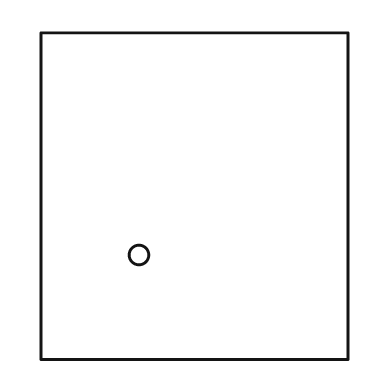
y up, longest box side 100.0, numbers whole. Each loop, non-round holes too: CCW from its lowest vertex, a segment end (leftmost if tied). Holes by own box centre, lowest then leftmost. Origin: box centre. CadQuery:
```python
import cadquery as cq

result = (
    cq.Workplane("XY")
    .moveTo(-47.0, -50.0)
    .lineTo(47.0, -50.0)
    .lineTo(47.0, 50.0)
    .lineTo(-47.0, 50.0)
    .close()
    .moveTo(-17.0, -18.0)
    .circle(3.0)
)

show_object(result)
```